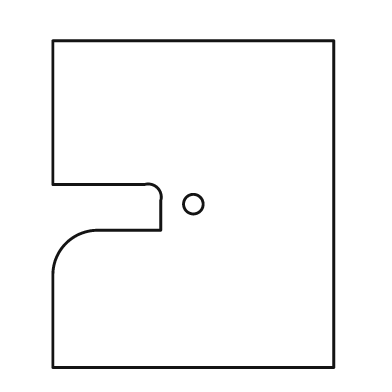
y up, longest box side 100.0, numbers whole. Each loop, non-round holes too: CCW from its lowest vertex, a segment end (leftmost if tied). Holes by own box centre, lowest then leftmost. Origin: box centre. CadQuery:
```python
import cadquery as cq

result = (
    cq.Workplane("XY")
    .moveTo(-43.0, -50.0)
    .lineTo(43.0, -50.0)
    .lineTo(43.0, 50.0)
    .lineTo(-43.0, 50.0)
    .lineTo(-43.0, 6.0)
    .lineTo(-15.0, 6.0)
    .threePointArc((-11.0, 5.0), (-10.0, 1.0))
    .lineTo(-10.0, -8.0)
    .lineTo(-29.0, -8.0)
    .threePointArc((-39.0, -12.0), (-43.0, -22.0))
    .close()
    .moveTo(0.0, 0.0)
    .circle(3.0)
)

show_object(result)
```